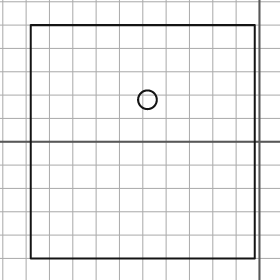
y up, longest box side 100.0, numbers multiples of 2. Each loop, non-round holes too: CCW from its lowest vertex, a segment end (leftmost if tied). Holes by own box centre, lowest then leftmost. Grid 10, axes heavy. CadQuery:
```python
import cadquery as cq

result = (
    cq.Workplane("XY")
    .moveTo(-98.0, -50.0)
    .lineTo(-2.0, -50.0)
    .lineTo(-2.0, 50.0)
    .lineTo(-98.0, 50.0)
    .close()
    .moveTo(-48.0, 18.0)
    .circle(4.0)
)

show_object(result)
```